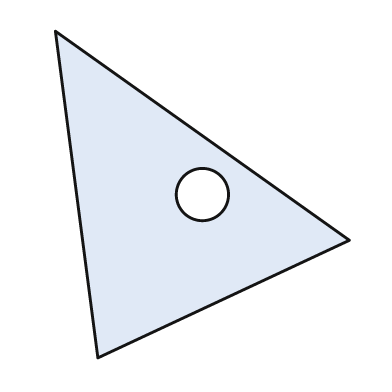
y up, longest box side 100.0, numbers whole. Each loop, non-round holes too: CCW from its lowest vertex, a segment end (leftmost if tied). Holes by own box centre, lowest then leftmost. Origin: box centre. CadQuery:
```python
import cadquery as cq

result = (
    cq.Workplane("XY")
    .moveTo(-32.0, -50.0)
    .lineTo(45.0, -14.0)
    .lineTo(-45.0, 50.0)
    .close()
    .moveTo(0.0, 0.0)
    .circle(8.0)
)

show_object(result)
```